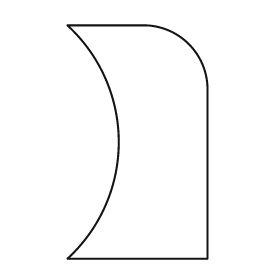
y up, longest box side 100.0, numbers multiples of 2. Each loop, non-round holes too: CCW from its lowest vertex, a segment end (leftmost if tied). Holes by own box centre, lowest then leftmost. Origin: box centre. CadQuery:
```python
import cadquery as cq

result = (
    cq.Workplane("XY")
    .moveTo(-30.0, -50.0)
    .lineTo(30.0, -50.0)
    .lineTo(30.0, 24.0)
    .threePointArc((22.0, 42.0), (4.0, 50.0))
    .lineTo(-30.0, 50.0)
    .threePointArc((-8.0, 0.0), (-30.0, -50.0))
    .close()
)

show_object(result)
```